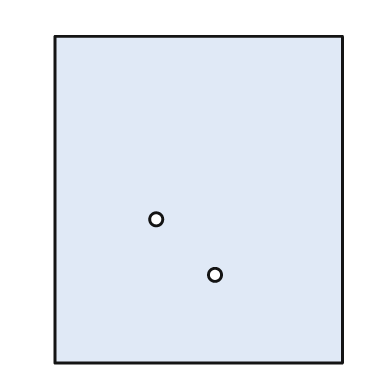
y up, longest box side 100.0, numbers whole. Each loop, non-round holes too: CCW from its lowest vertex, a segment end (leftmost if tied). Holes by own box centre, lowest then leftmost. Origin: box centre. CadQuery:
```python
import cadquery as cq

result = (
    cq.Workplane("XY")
    .moveTo(-44.0, -50.0)
    .lineTo(44.0, -50.0)
    .lineTo(44.0, 50.0)
    .lineTo(-44.0, 50.0)
    .close()
    .moveTo(5.0, -23.0)
    .circle(2.0)
    .moveTo(-13.0, -6.0)
    .circle(2.0)
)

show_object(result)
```